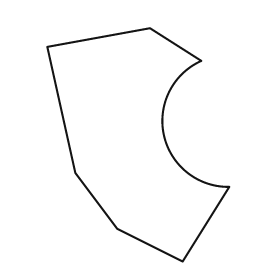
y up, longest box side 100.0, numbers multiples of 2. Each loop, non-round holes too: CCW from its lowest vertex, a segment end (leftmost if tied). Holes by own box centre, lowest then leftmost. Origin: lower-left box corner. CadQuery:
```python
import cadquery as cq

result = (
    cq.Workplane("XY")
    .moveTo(58.0, 0.0)
    .lineTo(78.0, 32.0)
    .threePointArc((50.0, 54.0), (66.0, 86.0))
    .lineTo(44.0, 100.0)
    .lineTo(0.0, 92.0)
    .lineTo(12.0, 38.0)
    .lineTo(30.0, 14.0)
    .close()
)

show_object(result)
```